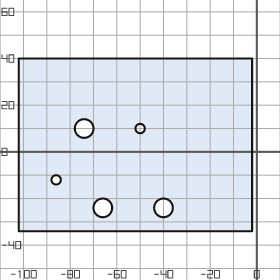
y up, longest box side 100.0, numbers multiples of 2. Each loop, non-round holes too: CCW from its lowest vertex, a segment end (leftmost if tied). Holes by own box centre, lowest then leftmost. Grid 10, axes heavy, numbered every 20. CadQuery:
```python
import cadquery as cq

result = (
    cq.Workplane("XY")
    .moveTo(-102.0, -34.0)
    .lineTo(-2.0, -34.0)
    .lineTo(-2.0, 40.0)
    .lineTo(-102.0, 40.0)
    .close()
    .moveTo(-66.0, -24.0)
    .circle(4.0)
    .moveTo(-40.0, -24.0)
    .circle(4.0)
    .moveTo(-86.0, -12.0)
    .circle(2.0)
    .moveTo(-74.0, 10.0)
    .circle(4.0)
    .moveTo(-50.0, 10.0)
    .circle(2.0)
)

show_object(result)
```